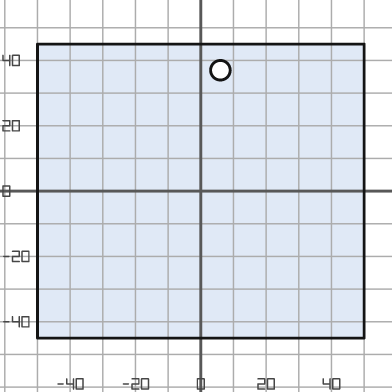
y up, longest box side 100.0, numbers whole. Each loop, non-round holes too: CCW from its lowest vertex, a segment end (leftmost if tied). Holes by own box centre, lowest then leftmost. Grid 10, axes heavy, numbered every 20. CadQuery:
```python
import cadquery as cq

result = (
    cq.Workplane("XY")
    .moveTo(-50.0, -45.0)
    .lineTo(50.0, -45.0)
    .lineTo(50.0, 45.0)
    .lineTo(-50.0, 45.0)
    .close()
    .moveTo(6.0, 37.0)
    .circle(3.0)
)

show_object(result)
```